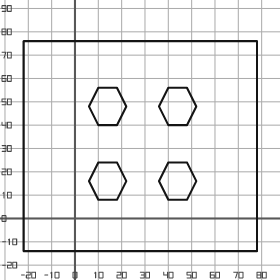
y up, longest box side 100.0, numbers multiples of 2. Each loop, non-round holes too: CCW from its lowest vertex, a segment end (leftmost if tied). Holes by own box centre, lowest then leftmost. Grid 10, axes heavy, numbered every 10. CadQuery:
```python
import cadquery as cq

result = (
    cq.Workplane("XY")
    .moveTo(-22.0, -14.0)
    .lineTo(78.0, -14.0)
    .lineTo(78.0, 76.0)
    .lineTo(-22.0, 76.0)
    .close()
    .moveTo(10.0, 8.0)
    .lineTo(18.0, 8.0)
    .lineTo(22.0, 16.0)
    .lineTo(18.0, 24.0)
    .lineTo(10.0, 24.0)
    .lineTo(6.0, 16.0)
    .close()
    .moveTo(40.0, 8.0)
    .lineTo(48.0, 8.0)
    .lineTo(52.0, 16.0)
    .lineTo(48.0, 24.0)
    .lineTo(40.0, 24.0)
    .lineTo(36.0, 16.0)
    .close()
    .moveTo(10.0, 40.0)
    .lineTo(18.0, 40.0)
    .lineTo(22.0, 48.0)
    .lineTo(18.0, 56.0)
    .lineTo(10.0, 56.0)
    .lineTo(6.0, 48.0)
    .close()
    .moveTo(40.0, 40.0)
    .lineTo(48.0, 40.0)
    .lineTo(52.0, 48.0)
    .lineTo(48.0, 56.0)
    .lineTo(40.0, 56.0)
    .lineTo(36.0, 48.0)
    .close()
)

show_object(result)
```